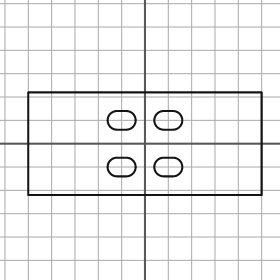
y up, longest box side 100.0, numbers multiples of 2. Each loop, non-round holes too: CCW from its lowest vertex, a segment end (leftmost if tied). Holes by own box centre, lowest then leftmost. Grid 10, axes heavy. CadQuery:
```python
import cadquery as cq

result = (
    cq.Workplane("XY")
    .moveTo(-50.0, -22.0)
    .lineTo(50.0, -22.0)
    .lineTo(50.0, 22.0)
    .lineTo(-50.0, 22.0)
    .close()
    .moveTo(-12.0, -14.0)
    .lineTo(-8.0, -14.0)
    .threePointArc((-4.0, -10.0), (-8.0, -6.0))
    .lineTo(-12.0, -6.0)
    .threePointArc((-16.0, -10.0), (-12.0, -14.0))
    .close()
    .moveTo(8.0, -14.0)
    .lineTo(12.0, -14.0)
    .threePointArc((16.0, -10.0), (12.0, -6.0))
    .lineTo(8.0, -6.0)
    .threePointArc((4.0, -10.0), (8.0, -14.0))
    .close()
    .moveTo(-12.0, 6.0)
    .lineTo(-8.0, 6.0)
    .threePointArc((-4.0, 10.0), (-8.0, 14.0))
    .lineTo(-12.0, 14.0)
    .threePointArc((-16.0, 10.0), (-12.0, 6.0))
    .close()
    .moveTo(8.0, 6.0)
    .lineTo(12.0, 6.0)
    .threePointArc((16.0, 10.0), (12.0, 14.0))
    .lineTo(8.0, 14.0)
    .threePointArc((4.0, 10.0), (8.0, 6.0))
    .close()
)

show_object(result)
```